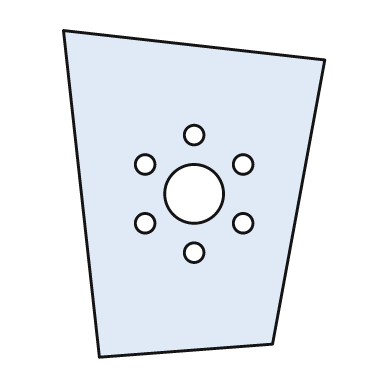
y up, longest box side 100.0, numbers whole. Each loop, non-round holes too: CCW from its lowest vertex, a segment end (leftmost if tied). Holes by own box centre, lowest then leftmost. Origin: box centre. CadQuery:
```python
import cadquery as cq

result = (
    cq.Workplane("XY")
    .moveTo(-29.0, -50.0)
    .lineTo(24.0, -46.0)
    .lineTo(40.0, 41.0)
    .lineTo(-40.0, 50.0)
    .close()
    .moveTo(0.0, -18.0)
    .circle(3.0)
    .moveTo(-15.0, -9.0)
    .circle(3.0)
    .moveTo(15.0, -9.0)
    .circle(3.0)
    .moveTo(0.0, 0.0)
    .circle(9.0)
    .moveTo(-15.0, 9.0)
    .circle(3.0)
    .moveTo(15.0, 9.0)
    .circle(3.0)
    .moveTo(0.0, 18.0)
    .circle(3.0)
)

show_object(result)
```